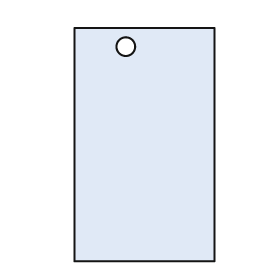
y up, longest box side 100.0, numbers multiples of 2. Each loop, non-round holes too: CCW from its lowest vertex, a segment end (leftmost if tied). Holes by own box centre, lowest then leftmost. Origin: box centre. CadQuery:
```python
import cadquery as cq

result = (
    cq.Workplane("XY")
    .moveTo(-30.0, -50.0)
    .lineTo(30.0, -50.0)
    .lineTo(30.0, 50.0)
    .lineTo(-30.0, 50.0)
    .close()
    .moveTo(-8.0, 42.0)
    .circle(4.0)
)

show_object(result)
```